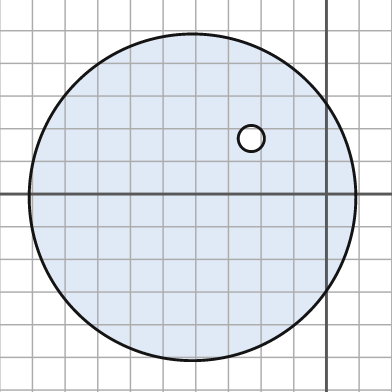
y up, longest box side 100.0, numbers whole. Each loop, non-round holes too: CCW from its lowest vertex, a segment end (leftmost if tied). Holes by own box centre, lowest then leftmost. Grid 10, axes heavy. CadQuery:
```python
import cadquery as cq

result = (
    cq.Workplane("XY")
    .moveTo(-41.0, -1.0)
    .circle(50.0)
    .moveTo(-23.0, 17.0)
    .circle(4.0)
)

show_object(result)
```